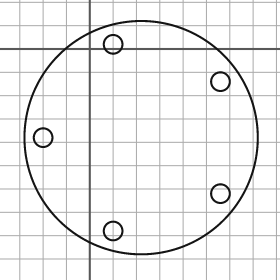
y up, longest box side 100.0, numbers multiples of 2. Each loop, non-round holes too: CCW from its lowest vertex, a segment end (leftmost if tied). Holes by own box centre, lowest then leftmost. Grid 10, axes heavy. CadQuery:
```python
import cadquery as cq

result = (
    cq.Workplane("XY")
    .moveTo(22.0, -38.0)
    .circle(50.0)
    .moveTo(10.0, -78.0)
    .circle(4.0)
    .moveTo(56.0, -62.0)
    .circle(4.0)
    .moveTo(-20.0, -38.0)
    .circle(4.0)
    .moveTo(56.0, -14.0)
    .circle(4.0)
    .moveTo(10.0, 2.0)
    .circle(4.0)
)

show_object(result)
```